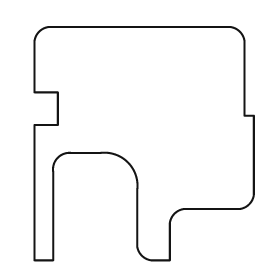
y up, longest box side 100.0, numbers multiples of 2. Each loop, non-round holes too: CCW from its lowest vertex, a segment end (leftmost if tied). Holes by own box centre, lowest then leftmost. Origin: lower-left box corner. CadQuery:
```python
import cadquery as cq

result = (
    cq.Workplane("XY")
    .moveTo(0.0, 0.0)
    .lineTo(8.0, 0.0)
    .lineTo(8.0, 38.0)
    .threePointArc((10.0, 44.0), (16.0, 46.0))
    .lineTo(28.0, 46.0)
    .threePointArc((40.0, 42.0), (44.0, 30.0))
    .lineTo(44.0, 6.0)
    .threePointArc((46.0, 2.0), (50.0, 0.0))
    .lineTo(58.0, 0.0)
    .lineTo(58.0, 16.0)
    .threePointArc((60.0, 20.0), (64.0, 22.0))
    .lineTo(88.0, 22.0)
    .threePointArc((92.0, 24.0), (94.0, 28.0))
    .lineTo(94.0, 62.0)
    .lineTo(90.0, 62.0)
    .lineTo(90.0, 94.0)
    .threePointArc((88.0, 98.0), (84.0, 100.0))
    .lineTo(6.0, 100.0)
    .threePointArc((2.0, 98.0), (0.0, 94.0))
    .lineTo(0.0, 72.0)
    .lineTo(10.0, 72.0)
    .lineTo(10.0, 58.0)
    .lineTo(0.0, 58.0)
    .close()
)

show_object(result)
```